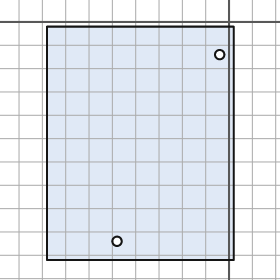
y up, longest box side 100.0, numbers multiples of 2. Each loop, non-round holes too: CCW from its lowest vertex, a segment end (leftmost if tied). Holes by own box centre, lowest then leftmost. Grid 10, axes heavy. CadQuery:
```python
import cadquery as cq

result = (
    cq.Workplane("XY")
    .moveTo(-78.0, -102.0)
    .lineTo(2.0, -102.0)
    .lineTo(2.0, -2.0)
    .lineTo(-78.0, -2.0)
    .close()
    .moveTo(-48.0, -94.0)
    .circle(2.0)
    .moveTo(-4.0, -14.0)
    .circle(2.0)
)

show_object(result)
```